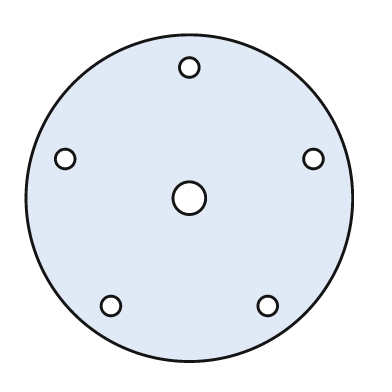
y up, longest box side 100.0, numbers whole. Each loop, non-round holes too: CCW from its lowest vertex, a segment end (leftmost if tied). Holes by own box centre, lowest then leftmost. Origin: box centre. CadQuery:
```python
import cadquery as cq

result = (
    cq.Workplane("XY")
    .moveTo(0.0, 0.0)
    .circle(50.0)
    .moveTo(-24.0, -33.0)
    .circle(3.0)
    .moveTo(24.0, -33.0)
    .circle(3.0)
    .moveTo(0.0, 0.0)
    .circle(5.0)
    .moveTo(-38.0, 12.0)
    .circle(3.0)
    .moveTo(38.0, 12.0)
    .circle(3.0)
    .moveTo(0.0, 40.0)
    .circle(3.0)
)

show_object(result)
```